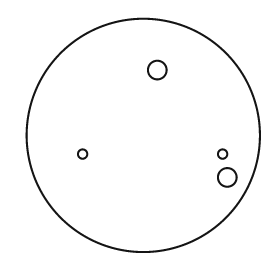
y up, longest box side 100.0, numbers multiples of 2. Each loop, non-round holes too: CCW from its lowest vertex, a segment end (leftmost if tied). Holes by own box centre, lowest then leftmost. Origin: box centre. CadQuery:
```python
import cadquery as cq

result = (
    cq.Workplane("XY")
    .moveTo(0.0, 0.0)
    .circle(50.0)
    .moveTo(36.0, -18.0)
    .circle(4.0)
    .moveTo(-26.0, -8.0)
    .circle(2.0)
    .moveTo(34.0, -8.0)
    .circle(2.0)
    .moveTo(6.0, 28.0)
    .circle(4.0)
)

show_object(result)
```